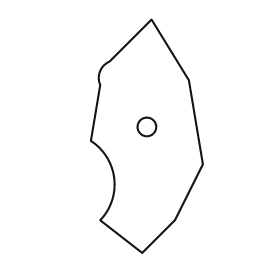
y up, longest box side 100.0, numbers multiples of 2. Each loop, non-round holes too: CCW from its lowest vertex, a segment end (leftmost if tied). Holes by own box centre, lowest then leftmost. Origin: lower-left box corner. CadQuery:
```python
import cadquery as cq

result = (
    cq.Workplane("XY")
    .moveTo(22.0, 0.0)
    .lineTo(36.0, 14.0)
    .lineTo(48.0, 38.0)
    .lineTo(42.0, 74.0)
    .lineTo(26.0, 100.0)
    .lineTo(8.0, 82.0)
    .threePointArc((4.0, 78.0), (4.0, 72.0))
    .lineTo(0.0, 48.0)
    .threePointArc((10.0, 32.0), (4.0, 14.0))
    .close()
    .moveTo(24.0, 54.0)
    .circle(4.0)
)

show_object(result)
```